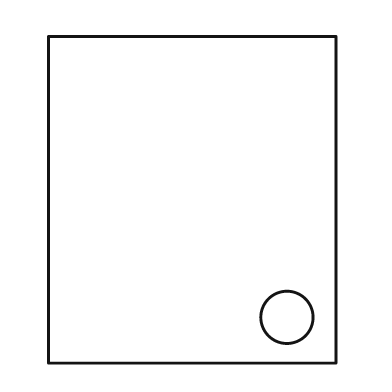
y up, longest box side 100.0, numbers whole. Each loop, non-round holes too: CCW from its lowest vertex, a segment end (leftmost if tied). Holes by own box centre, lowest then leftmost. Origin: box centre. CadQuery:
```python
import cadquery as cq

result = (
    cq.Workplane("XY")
    .moveTo(-44.0, -50.0)
    .lineTo(44.0, -50.0)
    .lineTo(44.0, 50.0)
    .lineTo(-44.0, 50.0)
    .close()
    .moveTo(29.0, -36.0)
    .circle(8.0)
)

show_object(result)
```